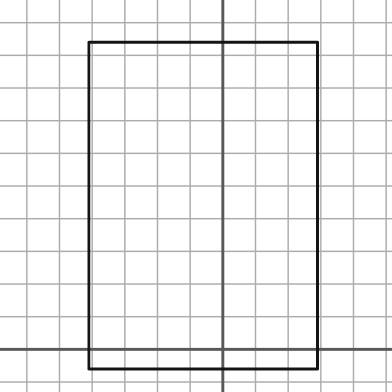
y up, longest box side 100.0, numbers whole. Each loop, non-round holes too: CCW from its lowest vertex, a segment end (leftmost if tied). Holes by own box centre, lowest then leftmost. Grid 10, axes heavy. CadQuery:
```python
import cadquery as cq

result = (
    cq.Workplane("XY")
    .moveTo(-41.0, -6.0)
    .lineTo(29.0, -6.0)
    .lineTo(29.0, 94.0)
    .lineTo(-41.0, 94.0)
    .close()
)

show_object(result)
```